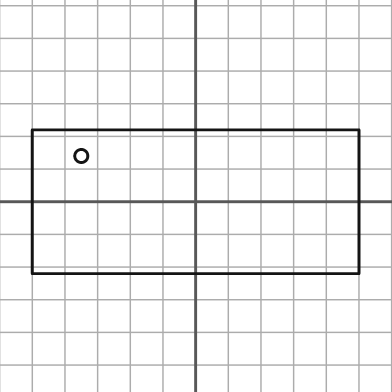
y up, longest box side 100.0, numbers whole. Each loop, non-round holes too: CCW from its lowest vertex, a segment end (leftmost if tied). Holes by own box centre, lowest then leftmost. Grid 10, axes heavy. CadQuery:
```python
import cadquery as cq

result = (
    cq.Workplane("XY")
    .moveTo(-50.0, -22.0)
    .lineTo(50.0, -22.0)
    .lineTo(50.0, 22.0)
    .lineTo(-50.0, 22.0)
    .close()
    .moveTo(-35.0, 14.0)
    .circle(2.0)
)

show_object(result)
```